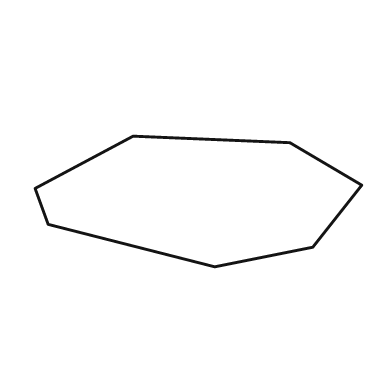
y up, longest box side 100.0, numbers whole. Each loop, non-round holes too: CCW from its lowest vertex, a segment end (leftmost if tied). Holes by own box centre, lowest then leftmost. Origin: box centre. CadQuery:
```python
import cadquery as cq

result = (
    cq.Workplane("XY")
    .moveTo(5.0, -20.0)
    .lineTo(35.0, -14.0)
    .lineTo(50.0, 5.0)
    .lineTo(28.0, 18.0)
    .lineTo(-20.0, 20.0)
    .lineTo(-50.0, 4.0)
    .lineTo(-46.0, -7.0)
    .close()
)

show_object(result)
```